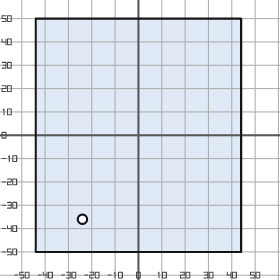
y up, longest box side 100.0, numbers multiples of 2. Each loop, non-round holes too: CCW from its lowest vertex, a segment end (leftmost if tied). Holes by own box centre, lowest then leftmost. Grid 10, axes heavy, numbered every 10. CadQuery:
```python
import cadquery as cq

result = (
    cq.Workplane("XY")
    .moveTo(-44.0, -50.0)
    .lineTo(44.0, -50.0)
    .lineTo(44.0, 50.0)
    .lineTo(-44.0, 50.0)
    .close()
    .moveTo(-24.0, -36.0)
    .circle(2.0)
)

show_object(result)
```